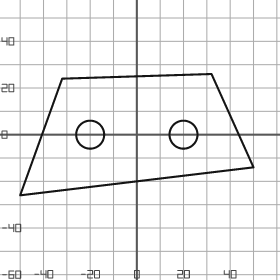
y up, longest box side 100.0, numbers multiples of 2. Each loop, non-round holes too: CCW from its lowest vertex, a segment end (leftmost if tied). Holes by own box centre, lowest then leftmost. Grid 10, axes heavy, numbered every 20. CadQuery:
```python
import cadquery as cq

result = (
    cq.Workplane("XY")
    .moveTo(-50.0, -26.0)
    .lineTo(50.0, -14.0)
    .lineTo(32.0, 26.0)
    .lineTo(-32.0, 24.0)
    .close()
    .moveTo(-20.0, 0.0)
    .circle(6.0)
    .moveTo(20.0, 0.0)
    .circle(6.0)
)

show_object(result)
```